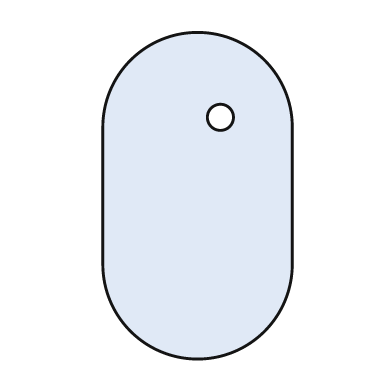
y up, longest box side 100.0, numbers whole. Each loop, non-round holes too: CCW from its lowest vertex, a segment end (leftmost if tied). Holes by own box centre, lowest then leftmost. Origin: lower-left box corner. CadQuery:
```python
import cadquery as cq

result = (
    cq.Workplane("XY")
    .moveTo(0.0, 29.0)
    .threePointArc((29.0, 0.0), (58.0, 29.0))
    .lineTo(58.0, 71.0)
    .threePointArc((29.0, 100.0), (0.0, 71.0))
    .close()
    .moveTo(36.0, 74.0)
    .circle(4.0)
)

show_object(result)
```